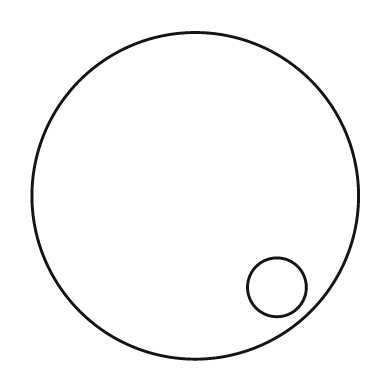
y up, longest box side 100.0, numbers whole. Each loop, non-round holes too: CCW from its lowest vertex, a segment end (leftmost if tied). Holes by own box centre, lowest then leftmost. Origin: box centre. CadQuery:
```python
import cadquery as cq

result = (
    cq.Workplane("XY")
    .moveTo(0.0, 0.0)
    .circle(50.0)
    .moveTo(25.0, -28.0)
    .circle(9.0)
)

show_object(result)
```